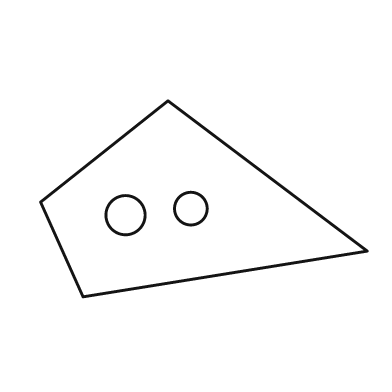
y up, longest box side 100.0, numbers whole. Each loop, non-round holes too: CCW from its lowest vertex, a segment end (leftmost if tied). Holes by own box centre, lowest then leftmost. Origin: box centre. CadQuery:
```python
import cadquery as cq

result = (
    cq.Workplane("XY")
    .moveTo(-37.0, -30.0)
    .lineTo(50.0, -16.0)
    .lineTo(-11.0, 30.0)
    .lineTo(-50.0, -1.0)
    .close()
    .moveTo(-24.0, -5.0)
    .circle(6.0)
    .moveTo(-4.0, -3.0)
    .circle(5.0)
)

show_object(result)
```